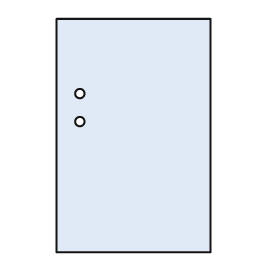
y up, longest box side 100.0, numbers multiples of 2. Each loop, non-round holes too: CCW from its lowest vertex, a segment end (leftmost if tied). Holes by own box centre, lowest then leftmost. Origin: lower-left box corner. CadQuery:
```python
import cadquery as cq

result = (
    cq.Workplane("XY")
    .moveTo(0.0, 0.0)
    .lineTo(66.0, 0.0)
    .lineTo(66.0, 100.0)
    .lineTo(0.0, 100.0)
    .close()
    .moveTo(10.0, 56.0)
    .circle(2.0)
    .moveTo(10.0, 68.0)
    .circle(2.0)
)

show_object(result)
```